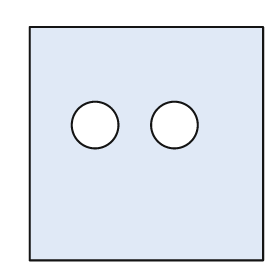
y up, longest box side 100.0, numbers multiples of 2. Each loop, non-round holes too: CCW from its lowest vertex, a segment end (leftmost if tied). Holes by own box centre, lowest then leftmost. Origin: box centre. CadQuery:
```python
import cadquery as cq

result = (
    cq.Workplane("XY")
    .moveTo(-50.0, -50.0)
    .lineTo(50.0, -50.0)
    .lineTo(50.0, 50.0)
    .lineTo(-50.0, 50.0)
    .close()
    .moveTo(-22.0, 8.0)
    .circle(10.0)
    .moveTo(12.0, 8.0)
    .circle(10.0)
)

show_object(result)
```